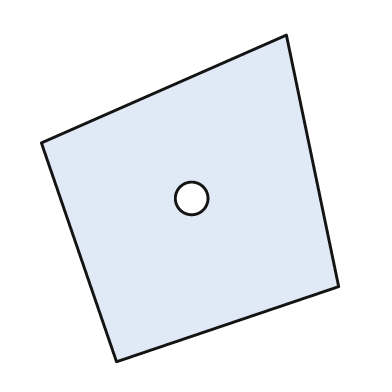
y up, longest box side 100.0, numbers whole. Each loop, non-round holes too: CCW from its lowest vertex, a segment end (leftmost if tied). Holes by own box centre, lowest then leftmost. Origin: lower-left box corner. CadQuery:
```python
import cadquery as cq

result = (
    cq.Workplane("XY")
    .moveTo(23.0, 0.0)
    .lineTo(91.0, 23.0)
    .lineTo(75.0, 100.0)
    .lineTo(0.0, 67.0)
    .close()
    .moveTo(46.0, 50.0)
    .circle(5.0)
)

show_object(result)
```